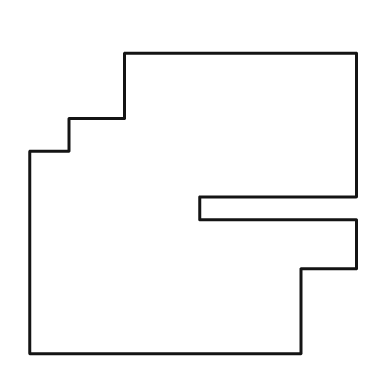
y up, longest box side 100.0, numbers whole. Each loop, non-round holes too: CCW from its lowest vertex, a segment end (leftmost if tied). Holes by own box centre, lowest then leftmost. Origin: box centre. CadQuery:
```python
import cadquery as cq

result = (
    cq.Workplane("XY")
    .moveTo(-50.0, -46.0)
    .lineTo(33.0, -46.0)
    .lineTo(33.0, -20.0)
    .lineTo(50.0, -20.0)
    .lineTo(50.0, -5.0)
    .lineTo(2.0, -5.0)
    .lineTo(2.0, 2.0)
    .lineTo(50.0, 2.0)
    .lineTo(50.0, 46.0)
    .lineTo(-21.0, 46.0)
    .lineTo(-21.0, 26.0)
    .lineTo(-38.0, 26.0)
    .lineTo(-38.0, 16.0)
    .lineTo(-50.0, 16.0)
    .close()
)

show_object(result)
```